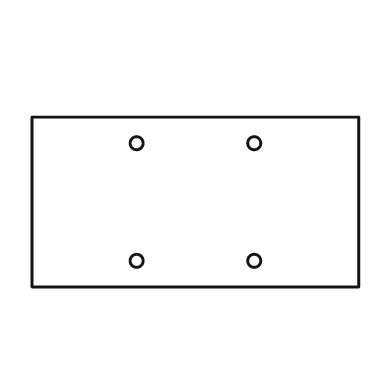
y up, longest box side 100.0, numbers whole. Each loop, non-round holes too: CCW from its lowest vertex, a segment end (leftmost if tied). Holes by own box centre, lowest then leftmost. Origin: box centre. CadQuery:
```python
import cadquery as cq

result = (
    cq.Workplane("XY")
    .moveTo(-50.0, -26.0)
    .lineTo(50.0, -26.0)
    .lineTo(50.0, 26.0)
    .lineTo(-50.0, 26.0)
    .close()
    .moveTo(-18.0, -18.0)
    .circle(2.0)
    .moveTo(18.0, -18.0)
    .circle(2.0)
    .moveTo(-18.0, 18.0)
    .circle(2.0)
    .moveTo(18.0, 18.0)
    .circle(2.0)
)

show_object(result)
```